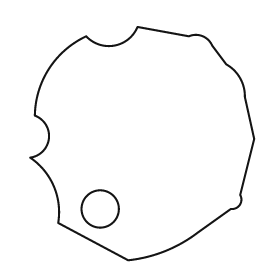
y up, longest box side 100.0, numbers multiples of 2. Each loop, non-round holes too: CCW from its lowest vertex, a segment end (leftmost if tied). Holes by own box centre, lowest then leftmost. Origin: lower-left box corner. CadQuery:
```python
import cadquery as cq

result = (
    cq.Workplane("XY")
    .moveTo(42.0, 0.0)
    .threePointArc((58.0, 4.0), (72.0, 12.0))
    .lineTo(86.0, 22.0)
    .threePointArc((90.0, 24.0), (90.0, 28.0))
    .lineTo(96.0, 52.0)
    .lineTo(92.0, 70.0)
    .threePointArc((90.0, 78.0), (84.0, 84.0))
    .lineTo(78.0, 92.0)
    .threePointArc((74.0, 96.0), (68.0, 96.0))
    .lineTo(46.0, 100.0)
    .threePointArc((36.0, 92.0), (24.0, 96.0))
    .threePointArc((8.0, 82.0), (2.0, 62.0))
    .threePointArc((8.0, 52.0), (0.0, 44.0))
    .threePointArc((10.0, 32.0), (12.0, 16.0))
    .close()
    .moveTo(30.0, 22.0)
    .circle(8.0)
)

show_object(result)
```